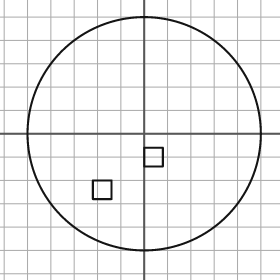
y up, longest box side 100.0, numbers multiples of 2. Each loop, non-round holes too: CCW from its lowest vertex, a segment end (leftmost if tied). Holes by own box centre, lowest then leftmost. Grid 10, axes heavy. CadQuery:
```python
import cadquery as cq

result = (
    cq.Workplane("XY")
    .moveTo(0.0, 0.0)
    .circle(50.0)
    .moveTo(-22.0, -28.0)
    .lineTo(-14.0, -28.0)
    .lineTo(-14.0, -20.0)
    .lineTo(-22.0, -20.0)
    .close()
    .moveTo(0.0, -14.0)
    .lineTo(8.0, -14.0)
    .lineTo(8.0, -6.0)
    .lineTo(0.0, -6.0)
    .close()
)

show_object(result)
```